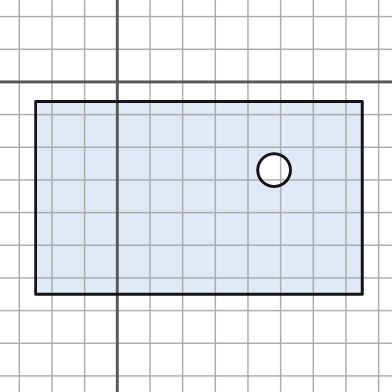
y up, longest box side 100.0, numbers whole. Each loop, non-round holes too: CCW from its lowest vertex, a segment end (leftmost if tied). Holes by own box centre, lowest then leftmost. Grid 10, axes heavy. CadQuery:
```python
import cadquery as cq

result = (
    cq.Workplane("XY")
    .moveTo(-25.0, -65.0)
    .lineTo(75.0, -65.0)
    .lineTo(75.0, -6.0)
    .lineTo(-25.0, -6.0)
    .close()
    .moveTo(48.0, -27.0)
    .circle(5.0)
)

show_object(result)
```